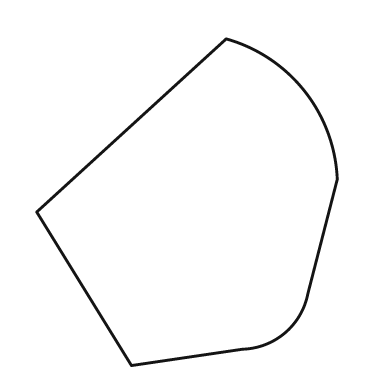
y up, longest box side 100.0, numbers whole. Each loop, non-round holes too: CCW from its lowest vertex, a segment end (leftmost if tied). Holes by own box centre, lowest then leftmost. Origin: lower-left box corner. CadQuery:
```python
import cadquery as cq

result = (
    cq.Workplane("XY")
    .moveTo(29.0, 0.0)
    .lineTo(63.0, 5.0)
    .threePointArc((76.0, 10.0), (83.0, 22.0))
    .lineTo(92.0, 57.0)
    .threePointArc((82.0, 84.0), (58.0, 100.0))
    .lineTo(0.0, 47.0)
    .close()
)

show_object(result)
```